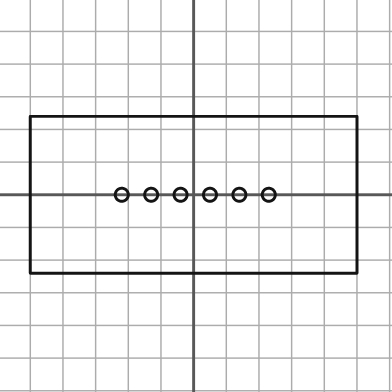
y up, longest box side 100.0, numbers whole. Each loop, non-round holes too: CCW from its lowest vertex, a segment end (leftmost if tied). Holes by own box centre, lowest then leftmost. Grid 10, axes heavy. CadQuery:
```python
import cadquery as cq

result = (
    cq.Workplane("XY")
    .moveTo(-50.0, -24.0)
    .lineTo(50.0, -24.0)
    .lineTo(50.0, 24.0)
    .lineTo(-50.0, 24.0)
    .close()
    .moveTo(-22.0, 0.0)
    .circle(2.0)
    .moveTo(-13.0, 0.0)
    .circle(2.0)
    .moveTo(-4.0, 0.0)
    .circle(2.0)
    .moveTo(5.0, 0.0)
    .circle(2.0)
    .moveTo(14.0, 0.0)
    .circle(2.0)
    .moveTo(23.0, 0.0)
    .circle(2.0)
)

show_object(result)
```